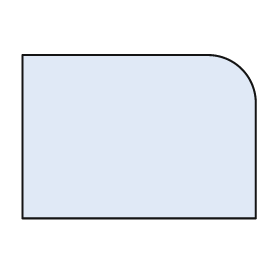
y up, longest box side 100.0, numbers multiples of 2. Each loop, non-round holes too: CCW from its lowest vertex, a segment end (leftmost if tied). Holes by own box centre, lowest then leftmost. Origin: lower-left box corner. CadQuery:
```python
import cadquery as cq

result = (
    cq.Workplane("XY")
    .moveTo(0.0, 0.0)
    .lineTo(100.0, 0.0)
    .lineTo(100.0, 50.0)
    .threePointArc((94.0, 64.0), (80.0, 70.0))
    .lineTo(0.0, 70.0)
    .close()
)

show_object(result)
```